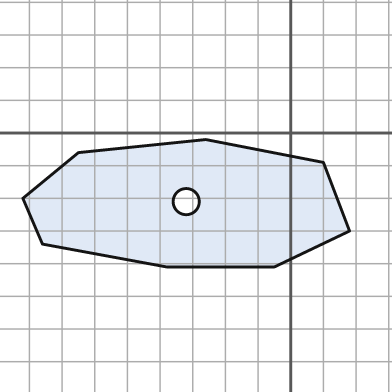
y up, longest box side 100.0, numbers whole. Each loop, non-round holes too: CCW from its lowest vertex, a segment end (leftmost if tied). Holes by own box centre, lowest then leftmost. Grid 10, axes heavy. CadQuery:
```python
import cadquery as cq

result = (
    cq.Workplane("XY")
    .moveTo(-38.0, -41.0)
    .lineTo(-5.0, -41.0)
    .lineTo(18.0, -30.0)
    .lineTo(10.0, -9.0)
    .lineTo(-26.0, -2.0)
    .lineTo(-65.0, -6.0)
    .lineTo(-82.0, -20.0)
    .lineTo(-76.0, -34.0)
    .close()
    .moveTo(-32.0, -21.0)
    .circle(4.0)
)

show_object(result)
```